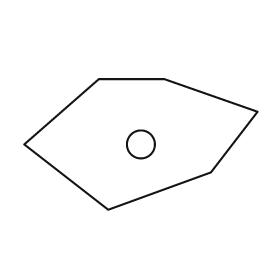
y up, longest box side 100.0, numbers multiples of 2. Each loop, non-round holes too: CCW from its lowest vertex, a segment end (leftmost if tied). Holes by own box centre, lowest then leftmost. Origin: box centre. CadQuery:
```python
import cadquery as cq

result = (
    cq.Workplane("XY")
    .moveTo(-14.0, -28.0)
    .lineTo(30.0, -12.0)
    .lineTo(50.0, 14.0)
    .lineTo(10.0, 28.0)
    .lineTo(-18.0, 28.0)
    .lineTo(-50.0, 0.0)
    .close()
    .moveTo(0.0, 0.0)
    .circle(6.0)
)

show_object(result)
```